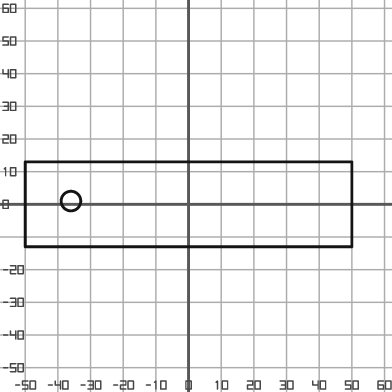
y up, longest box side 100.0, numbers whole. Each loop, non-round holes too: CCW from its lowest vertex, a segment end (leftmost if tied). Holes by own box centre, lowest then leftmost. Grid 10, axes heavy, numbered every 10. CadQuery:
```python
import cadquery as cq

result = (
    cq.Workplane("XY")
    .moveTo(-50.0, -13.0)
    .lineTo(50.0, -13.0)
    .lineTo(50.0, 13.0)
    .lineTo(-50.0, 13.0)
    .close()
    .moveTo(-36.0, 1.0)
    .circle(3.0)
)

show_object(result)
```